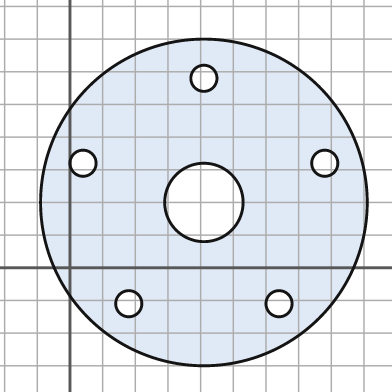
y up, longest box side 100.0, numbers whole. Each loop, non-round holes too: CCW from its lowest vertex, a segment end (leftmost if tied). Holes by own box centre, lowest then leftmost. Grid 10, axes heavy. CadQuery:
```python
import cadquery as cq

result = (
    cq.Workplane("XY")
    .moveTo(41.0, 20.0)
    .circle(50.0)
    .moveTo(18.0, -11.0)
    .circle(4.0)
    .moveTo(64.0, -11.0)
    .circle(4.0)
    .moveTo(41.0, 20.0)
    .circle(12.0)
    .moveTo(4.0, 32.0)
    .circle(4.0)
    .moveTo(78.0, 32.0)
    .circle(4.0)
    .moveTo(41.0, 58.0)
    .circle(4.0)
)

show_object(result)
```